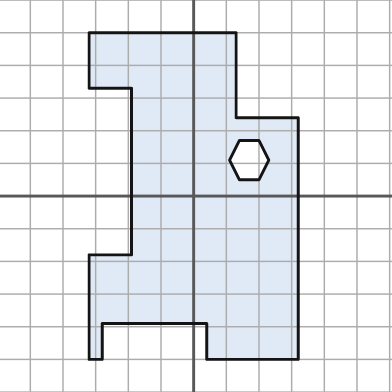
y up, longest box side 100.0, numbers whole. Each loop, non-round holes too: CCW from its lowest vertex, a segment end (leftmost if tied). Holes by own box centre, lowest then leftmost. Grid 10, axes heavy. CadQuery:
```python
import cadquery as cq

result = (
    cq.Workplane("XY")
    .moveTo(-32.0, -50.0)
    .lineTo(-28.0, -50.0)
    .lineTo(-28.0, -39.0)
    .lineTo(4.0, -39.0)
    .lineTo(4.0, -50.0)
    .lineTo(32.0, -50.0)
    .lineTo(32.0, 24.0)
    .lineTo(13.0, 24.0)
    .lineTo(13.0, 50.0)
    .lineTo(-32.0, 50.0)
    .lineTo(-32.0, 33.0)
    .lineTo(-19.0, 33.0)
    .lineTo(-19.0, -18.0)
    .lineTo(-32.0, -18.0)
    .close()
    .moveTo(14.0, 5.0)
    .lineTo(20.0, 5.0)
    .lineTo(23.0, 11.0)
    .lineTo(20.0, 17.0)
    .lineTo(14.0, 17.0)
    .lineTo(11.0, 11.0)
    .close()
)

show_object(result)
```